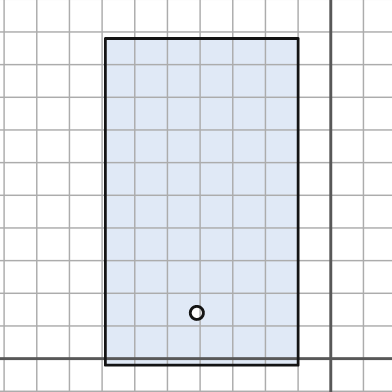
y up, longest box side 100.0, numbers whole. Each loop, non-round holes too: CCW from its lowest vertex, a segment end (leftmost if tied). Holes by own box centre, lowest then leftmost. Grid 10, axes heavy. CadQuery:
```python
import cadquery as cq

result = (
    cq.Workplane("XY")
    .moveTo(-69.0, -2.0)
    .lineTo(-10.0, -2.0)
    .lineTo(-10.0, 98.0)
    .lineTo(-69.0, 98.0)
    .close()
    .moveTo(-41.0, 14.0)
    .circle(2.0)
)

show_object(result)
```